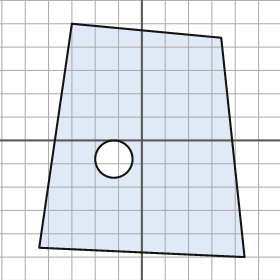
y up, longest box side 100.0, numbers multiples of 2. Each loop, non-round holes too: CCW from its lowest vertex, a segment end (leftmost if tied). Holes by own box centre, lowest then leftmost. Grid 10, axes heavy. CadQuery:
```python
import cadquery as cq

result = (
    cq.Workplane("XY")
    .moveTo(44.0, -50.0)
    .lineTo(34.0, 44.0)
    .lineTo(-30.0, 50.0)
    .lineTo(-44.0, -46.0)
    .close()
    .moveTo(-12.0, -8.0)
    .circle(8.0)
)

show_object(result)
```